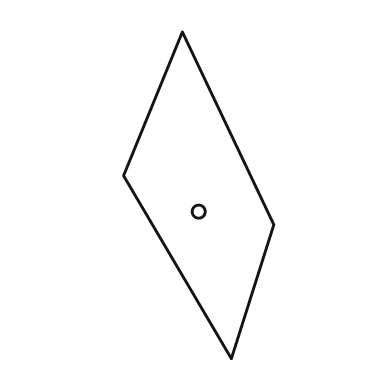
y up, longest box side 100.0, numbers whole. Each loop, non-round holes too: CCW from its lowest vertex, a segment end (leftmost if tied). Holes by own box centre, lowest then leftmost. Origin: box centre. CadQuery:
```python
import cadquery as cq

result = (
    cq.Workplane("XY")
    .moveTo(10.0, -50.0)
    .lineTo(23.0, -9.0)
    .lineTo(-5.0, 50.0)
    .lineTo(-23.0, 6.0)
    .close()
    .moveTo(0.0, -5.0)
    .circle(2.0)
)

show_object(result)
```